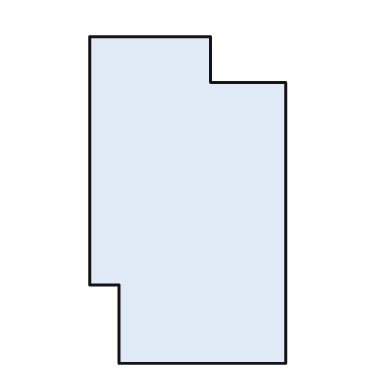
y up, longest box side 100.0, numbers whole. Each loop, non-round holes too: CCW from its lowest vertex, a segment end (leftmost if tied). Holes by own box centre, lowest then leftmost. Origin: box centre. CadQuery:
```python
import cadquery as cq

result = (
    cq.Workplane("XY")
    .moveTo(-21.0, -50.0)
    .lineTo(30.0, -50.0)
    .lineTo(30.0, 36.0)
    .lineTo(7.0, 36.0)
    .lineTo(7.0, 50.0)
    .lineTo(-30.0, 50.0)
    .lineTo(-30.0, -26.0)
    .lineTo(-21.0, -26.0)
    .close()
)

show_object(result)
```